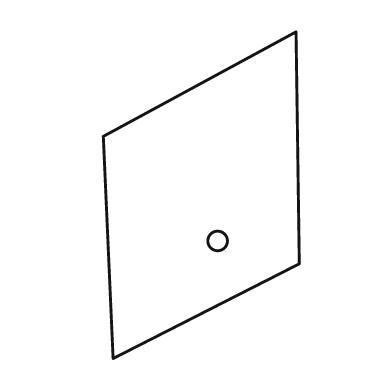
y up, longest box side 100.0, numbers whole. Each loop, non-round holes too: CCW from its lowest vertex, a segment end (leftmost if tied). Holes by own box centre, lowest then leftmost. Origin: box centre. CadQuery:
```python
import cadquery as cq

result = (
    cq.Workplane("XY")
    .moveTo(-27.0, -50.0)
    .lineTo(30.0, -21.0)
    .lineTo(29.0, 50.0)
    .lineTo(-30.0, 18.0)
    .close()
    .moveTo(5.0, -14.0)
    .circle(3.0)
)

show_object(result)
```